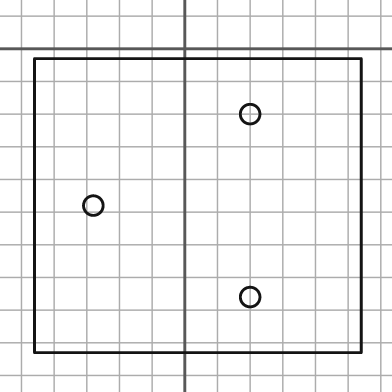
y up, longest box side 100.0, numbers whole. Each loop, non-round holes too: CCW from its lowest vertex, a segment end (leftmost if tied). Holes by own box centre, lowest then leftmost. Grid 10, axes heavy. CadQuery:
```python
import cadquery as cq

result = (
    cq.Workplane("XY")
    .moveTo(-46.0, -93.0)
    .lineTo(54.0, -93.0)
    .lineTo(54.0, -3.0)
    .lineTo(-46.0, -3.0)
    .close()
    .moveTo(20.0, -76.0)
    .circle(3.0)
    .moveTo(-28.0, -48.0)
    .circle(3.0)
    .moveTo(20.0, -20.0)
    .circle(3.0)
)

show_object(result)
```